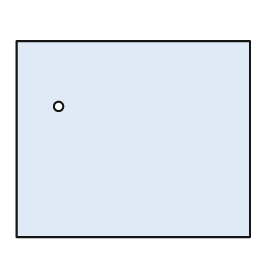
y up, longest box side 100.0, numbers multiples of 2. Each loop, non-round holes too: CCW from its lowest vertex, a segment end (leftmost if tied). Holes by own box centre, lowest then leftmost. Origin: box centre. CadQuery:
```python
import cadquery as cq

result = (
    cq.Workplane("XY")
    .moveTo(-50.0, -42.0)
    .lineTo(50.0, -42.0)
    .lineTo(50.0, 42.0)
    .lineTo(-50.0, 42.0)
    .close()
    .moveTo(-32.0, 14.0)
    .circle(2.0)
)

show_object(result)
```